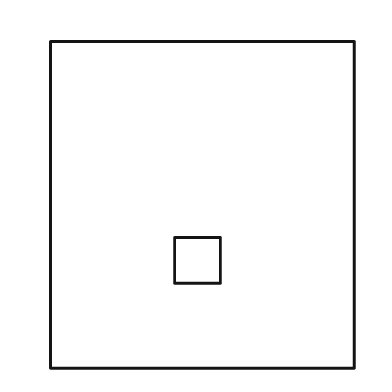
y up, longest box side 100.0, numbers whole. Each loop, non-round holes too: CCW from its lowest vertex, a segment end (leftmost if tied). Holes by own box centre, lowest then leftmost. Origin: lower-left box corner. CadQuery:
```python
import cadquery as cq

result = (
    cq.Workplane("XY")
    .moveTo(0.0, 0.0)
    .lineTo(93.0, 0.0)
    .lineTo(93.0, 100.0)
    .lineTo(0.0, 100.0)
    .close()
    .moveTo(38.0, 26.0)
    .lineTo(52.0, 26.0)
    .lineTo(52.0, 40.0)
    .lineTo(38.0, 40.0)
    .close()
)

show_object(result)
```